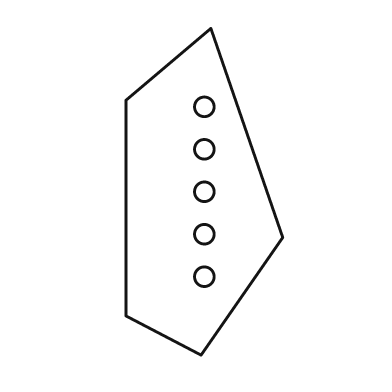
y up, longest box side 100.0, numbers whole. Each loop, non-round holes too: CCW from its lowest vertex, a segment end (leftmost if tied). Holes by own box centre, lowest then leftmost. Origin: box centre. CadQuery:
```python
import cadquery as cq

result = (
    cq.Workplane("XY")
    .moveTo(-1.0, -50.0)
    .lineTo(24.0, -14.0)
    .lineTo(2.0, 50.0)
    .lineTo(-24.0, 28.0)
    .lineTo(-24.0, -38.0)
    .close()
    .moveTo(0.0, -26.0)
    .circle(3.0)
    .moveTo(0.0, -13.0)
    .circle(3.0)
    .moveTo(0.0, 0.0)
    .circle(3.0)
    .moveTo(0.0, 13.0)
    .circle(3.0)
    .moveTo(0.0, 26.0)
    .circle(3.0)
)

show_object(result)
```